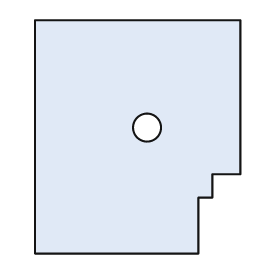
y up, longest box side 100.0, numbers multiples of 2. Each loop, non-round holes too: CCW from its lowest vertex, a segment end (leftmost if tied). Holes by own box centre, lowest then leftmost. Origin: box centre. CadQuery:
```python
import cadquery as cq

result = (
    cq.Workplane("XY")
    .moveTo(-44.0, -50.0)
    .lineTo(26.0, -50.0)
    .lineTo(26.0, -26.0)
    .lineTo(32.0, -26.0)
    .lineTo(32.0, -16.0)
    .lineTo(44.0, -16.0)
    .lineTo(44.0, 50.0)
    .lineTo(-44.0, 50.0)
    .close()
    .moveTo(4.0, 4.0)
    .circle(6.0)
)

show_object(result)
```